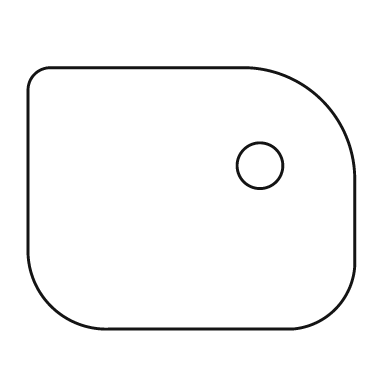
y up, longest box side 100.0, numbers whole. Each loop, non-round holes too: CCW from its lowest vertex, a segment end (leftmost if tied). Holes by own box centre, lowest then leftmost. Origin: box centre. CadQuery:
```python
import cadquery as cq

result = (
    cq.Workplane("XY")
    .moveTo(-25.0, -40.0)
    .lineTo(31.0, -40.0)
    .threePointArc((44.0, -34.0), (50.0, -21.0))
    .lineTo(50.0, 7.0)
    .threePointArc((40.0, 30.0), (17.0, 40.0))
    .lineTo(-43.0, 40.0)
    .threePointArc((-48.0, 38.0), (-50.0, 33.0))
    .lineTo(-50.0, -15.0)
    .threePointArc((-43.0, -33.0), (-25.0, -40.0))
    .close()
    .moveTo(21.0, 10.0)
    .circle(7.0)
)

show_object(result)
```